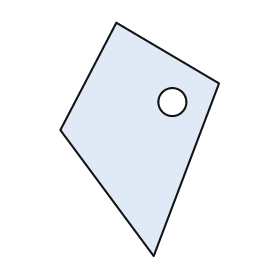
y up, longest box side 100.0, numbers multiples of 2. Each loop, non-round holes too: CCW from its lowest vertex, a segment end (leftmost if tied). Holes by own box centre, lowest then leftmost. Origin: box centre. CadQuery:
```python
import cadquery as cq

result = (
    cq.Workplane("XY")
    .moveTo(6.0, -50.0)
    .lineTo(34.0, 24.0)
    .lineTo(-10.0, 50.0)
    .lineTo(-34.0, 4.0)
    .close()
    .moveTo(14.0, 16.0)
    .circle(6.0)
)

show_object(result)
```